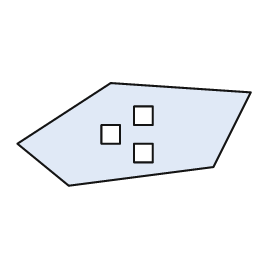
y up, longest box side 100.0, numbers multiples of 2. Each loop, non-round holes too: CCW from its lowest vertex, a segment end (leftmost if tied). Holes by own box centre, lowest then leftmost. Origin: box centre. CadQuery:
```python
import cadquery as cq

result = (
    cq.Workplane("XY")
    .moveTo(-28.0, -22.0)
    .lineTo(34.0, -14.0)
    .lineTo(50.0, 18.0)
    .lineTo(-10.0, 22.0)
    .lineTo(-50.0, -4.0)
    .close()
    .moveTo(0.0, -12.0)
    .lineTo(8.0, -12.0)
    .lineTo(8.0, -4.0)
    .lineTo(0.0, -4.0)
    .close()
    .moveTo(-14.0, -4.0)
    .lineTo(-6.0, -4.0)
    .lineTo(-6.0, 4.0)
    .lineTo(-14.0, 4.0)
    .close()
    .moveTo(0.0, 4.0)
    .lineTo(8.0, 4.0)
    .lineTo(8.0, 12.0)
    .lineTo(0.0, 12.0)
    .close()
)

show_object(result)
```